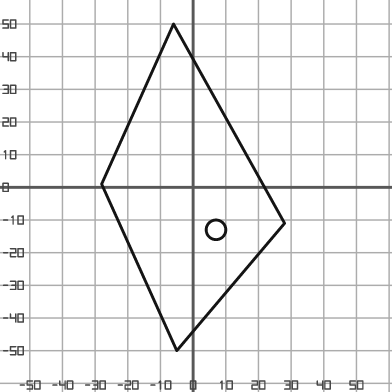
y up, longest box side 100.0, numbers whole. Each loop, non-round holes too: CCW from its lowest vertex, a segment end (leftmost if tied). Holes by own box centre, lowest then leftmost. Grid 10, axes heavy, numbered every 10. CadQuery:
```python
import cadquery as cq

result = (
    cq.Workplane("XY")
    .moveTo(-5.0, -50.0)
    .lineTo(28.0, -11.0)
    .lineTo(-6.0, 50.0)
    .lineTo(-28.0, 1.0)
    .close()
    .moveTo(7.0, -13.0)
    .circle(3.0)
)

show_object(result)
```